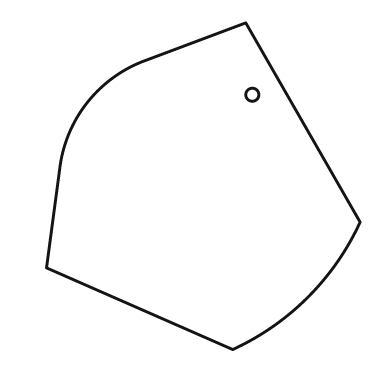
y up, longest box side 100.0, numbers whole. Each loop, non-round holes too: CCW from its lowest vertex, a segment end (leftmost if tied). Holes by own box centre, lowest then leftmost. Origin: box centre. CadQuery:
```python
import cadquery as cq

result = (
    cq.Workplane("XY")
    .moveTo(9.0, -50.0)
    .threePointArc((32.0, -34.0), (48.0, -11.0))
    .lineTo(13.0, 50.0)
    .lineTo(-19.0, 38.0)
    .threePointArc((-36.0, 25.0), (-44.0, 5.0))
    .lineTo(-48.0, -25.0)
    .close()
    .moveTo(15.0, 28.0)
    .circle(2.0)
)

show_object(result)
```